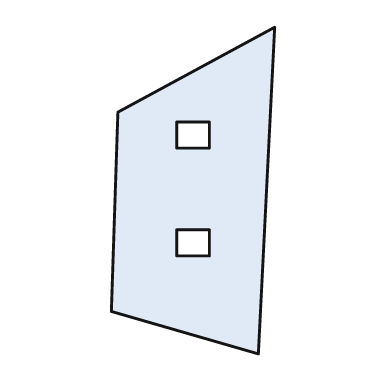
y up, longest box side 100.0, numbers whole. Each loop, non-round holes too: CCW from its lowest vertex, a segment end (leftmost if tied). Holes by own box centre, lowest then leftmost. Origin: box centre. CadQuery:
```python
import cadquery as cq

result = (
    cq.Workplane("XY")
    .moveTo(20.0, -50.0)
    .lineTo(25.0, 50.0)
    .lineTo(-23.0, 24.0)
    .lineTo(-25.0, -37.0)
    .close()
    .moveTo(-5.0, -20.0)
    .lineTo(5.0, -20.0)
    .lineTo(5.0, -12.0)
    .lineTo(-5.0, -12.0)
    .close()
    .moveTo(-5.0, 13.0)
    .lineTo(5.0, 13.0)
    .lineTo(5.0, 21.0)
    .lineTo(-5.0, 21.0)
    .close()
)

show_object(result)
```